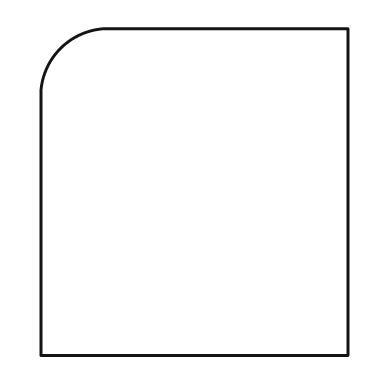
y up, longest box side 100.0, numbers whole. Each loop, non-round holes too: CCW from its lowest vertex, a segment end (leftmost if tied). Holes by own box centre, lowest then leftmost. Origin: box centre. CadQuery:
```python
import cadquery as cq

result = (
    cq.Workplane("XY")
    .moveTo(-47.0, -50.0)
    .lineTo(47.0, -50.0)
    .lineTo(47.0, 50.0)
    .lineTo(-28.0, 50.0)
    .threePointArc((-41.0, 44.0), (-47.0, 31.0))
    .close()
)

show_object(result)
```